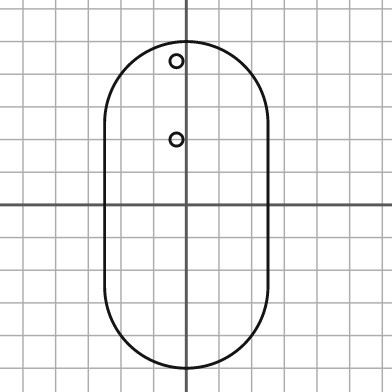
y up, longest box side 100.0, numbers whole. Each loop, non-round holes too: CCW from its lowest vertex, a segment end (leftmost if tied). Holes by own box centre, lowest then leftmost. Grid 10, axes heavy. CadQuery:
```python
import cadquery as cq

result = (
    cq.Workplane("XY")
    .moveTo(-25.0, -25.0)
    .threePointArc((0.0, -50.0), (25.0, -25.0))
    .lineTo(25.0, 25.0)
    .threePointArc((0.0, 50.0), (-25.0, 25.0))
    .close()
    .moveTo(-3.0, 20.0)
    .circle(2.0)
    .moveTo(-3.0, 44.0)
    .circle(2.0)
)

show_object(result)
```